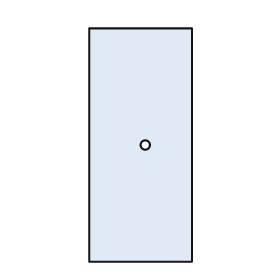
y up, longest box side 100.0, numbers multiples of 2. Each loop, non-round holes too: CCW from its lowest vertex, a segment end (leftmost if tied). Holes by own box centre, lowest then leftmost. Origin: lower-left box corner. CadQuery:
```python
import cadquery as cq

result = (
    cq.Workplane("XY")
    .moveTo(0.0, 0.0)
    .lineTo(44.0, 0.0)
    .lineTo(44.0, 100.0)
    .lineTo(0.0, 100.0)
    .close()
    .moveTo(24.0, 50.0)
    .circle(2.0)
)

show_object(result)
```